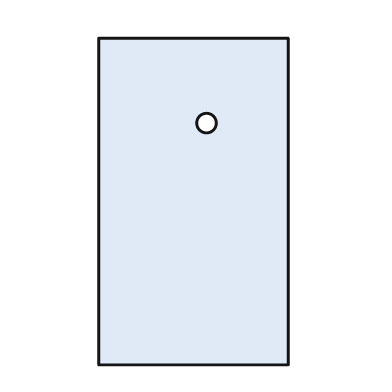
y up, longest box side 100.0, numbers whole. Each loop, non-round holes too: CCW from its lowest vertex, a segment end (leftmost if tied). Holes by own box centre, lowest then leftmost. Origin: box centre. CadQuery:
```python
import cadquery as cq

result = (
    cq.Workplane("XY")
    .moveTo(-29.0, -50.0)
    .lineTo(29.0, -50.0)
    .lineTo(29.0, 50.0)
    .lineTo(-29.0, 50.0)
    .close()
    .moveTo(4.0, 24.0)
    .circle(3.0)
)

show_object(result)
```